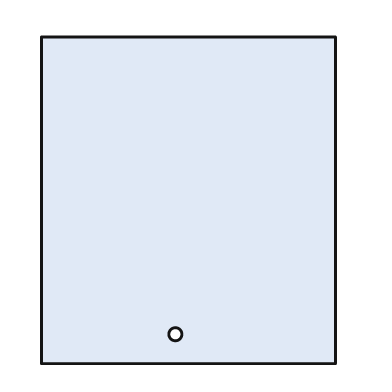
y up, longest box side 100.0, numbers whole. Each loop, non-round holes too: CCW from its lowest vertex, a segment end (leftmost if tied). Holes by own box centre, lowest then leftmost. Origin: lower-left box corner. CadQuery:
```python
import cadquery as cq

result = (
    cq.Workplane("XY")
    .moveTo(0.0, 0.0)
    .lineTo(90.0, 0.0)
    .lineTo(90.0, 100.0)
    .lineTo(0.0, 100.0)
    .close()
    .moveTo(41.0, 9.0)
    .circle(2.0)
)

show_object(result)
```